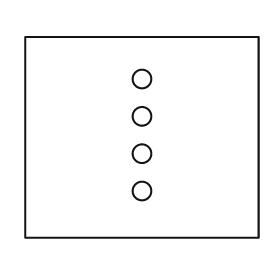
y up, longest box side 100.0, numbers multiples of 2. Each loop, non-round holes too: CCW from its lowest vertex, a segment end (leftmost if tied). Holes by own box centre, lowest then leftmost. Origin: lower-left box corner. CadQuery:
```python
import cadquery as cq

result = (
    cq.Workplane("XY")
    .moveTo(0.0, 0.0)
    .lineTo(100.0, 0.0)
    .lineTo(100.0, 86.0)
    .lineTo(0.0, 86.0)
    .close()
    .moveTo(50.0, 20.0)
    .circle(4.0)
    .moveTo(50.0, 36.0)
    .circle(4.0)
    .moveTo(50.0, 52.0)
    .circle(4.0)
    .moveTo(50.0, 68.0)
    .circle(4.0)
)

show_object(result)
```